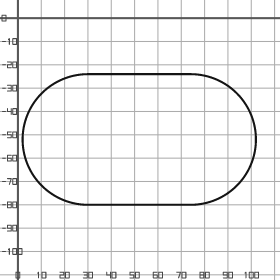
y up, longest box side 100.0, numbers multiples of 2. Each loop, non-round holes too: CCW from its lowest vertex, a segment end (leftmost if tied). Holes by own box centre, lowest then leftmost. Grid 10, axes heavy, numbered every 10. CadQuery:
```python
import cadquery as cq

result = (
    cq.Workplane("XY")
    .moveTo(30.0, -80.0)
    .lineTo(74.0, -80.0)
    .threePointArc((102.0, -52.0), (74.0, -24.0))
    .lineTo(30.0, -24.0)
    .threePointArc((2.0, -52.0), (30.0, -80.0))
    .close()
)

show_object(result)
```